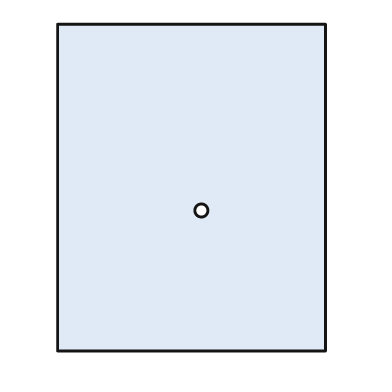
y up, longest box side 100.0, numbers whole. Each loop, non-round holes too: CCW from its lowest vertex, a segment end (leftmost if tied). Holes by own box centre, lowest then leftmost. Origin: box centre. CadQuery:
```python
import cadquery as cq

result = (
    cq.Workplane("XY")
    .moveTo(-41.0, -50.0)
    .lineTo(41.0, -50.0)
    .lineTo(41.0, 50.0)
    .lineTo(-41.0, 50.0)
    .close()
    .moveTo(3.0, -7.0)
    .circle(2.0)
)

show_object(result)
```